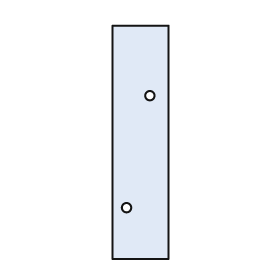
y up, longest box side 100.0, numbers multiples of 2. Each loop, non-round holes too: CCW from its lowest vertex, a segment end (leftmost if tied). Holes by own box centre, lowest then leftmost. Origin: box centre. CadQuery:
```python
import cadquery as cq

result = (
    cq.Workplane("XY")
    .moveTo(-12.0, -50.0)
    .lineTo(12.0, -50.0)
    .lineTo(12.0, 50.0)
    .lineTo(-12.0, 50.0)
    .close()
    .moveTo(-6.0, -28.0)
    .circle(2.0)
    .moveTo(4.0, 20.0)
    .circle(2.0)
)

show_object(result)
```